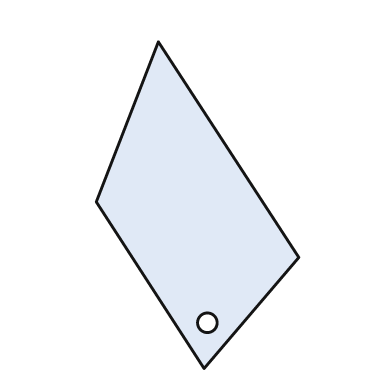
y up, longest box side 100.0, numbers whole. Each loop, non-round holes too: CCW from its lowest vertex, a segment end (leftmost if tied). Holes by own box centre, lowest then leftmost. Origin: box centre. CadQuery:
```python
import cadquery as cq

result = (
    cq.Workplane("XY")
    .moveTo(2.0, -50.0)
    .lineTo(31.0, -16.0)
    .lineTo(-12.0, 50.0)
    .lineTo(-31.0, 1.0)
    .close()
    .moveTo(3.0, -36.0)
    .circle(3.0)
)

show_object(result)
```